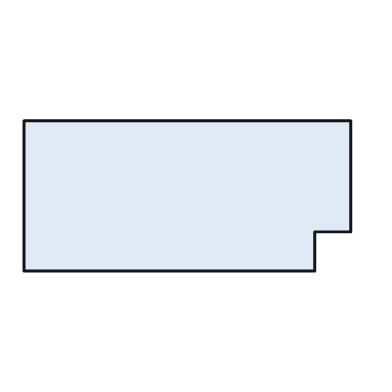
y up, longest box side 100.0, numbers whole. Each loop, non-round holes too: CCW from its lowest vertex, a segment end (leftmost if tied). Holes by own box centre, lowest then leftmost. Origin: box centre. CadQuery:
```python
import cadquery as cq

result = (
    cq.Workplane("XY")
    .moveTo(-50.0, -23.0)
    .lineTo(39.0, -23.0)
    .lineTo(39.0, -11.0)
    .lineTo(50.0, -11.0)
    .lineTo(50.0, 23.0)
    .lineTo(-50.0, 23.0)
    .close()
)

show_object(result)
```